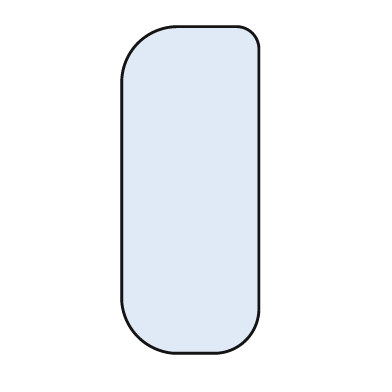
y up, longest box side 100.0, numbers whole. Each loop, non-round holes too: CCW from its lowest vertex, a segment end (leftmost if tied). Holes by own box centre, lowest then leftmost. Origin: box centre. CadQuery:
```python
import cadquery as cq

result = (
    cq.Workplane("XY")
    .moveTo(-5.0, -50.0)
    .lineTo(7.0, -50.0)
    .threePointArc((17.0, -46.0), (21.0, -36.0))
    .lineTo(21.0, 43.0)
    .threePointArc((19.0, 48.0), (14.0, 50.0))
    .lineTo(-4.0, 50.0)
    .threePointArc((-16.0, 45.0), (-21.0, 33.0))
    .lineTo(-21.0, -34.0)
    .threePointArc((-16.0, -45.0), (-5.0, -50.0))
    .close()
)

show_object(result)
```